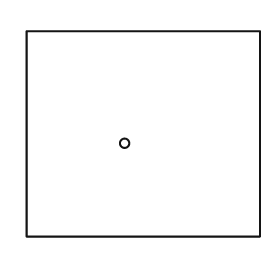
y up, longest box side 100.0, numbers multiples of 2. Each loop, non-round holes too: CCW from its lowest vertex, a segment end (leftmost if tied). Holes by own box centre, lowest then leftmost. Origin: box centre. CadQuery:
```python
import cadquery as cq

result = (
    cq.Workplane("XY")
    .moveTo(-50.0, -44.0)
    .lineTo(50.0, -44.0)
    .lineTo(50.0, 44.0)
    .lineTo(-50.0, 44.0)
    .close()
    .moveTo(-8.0, -4.0)
    .circle(2.0)
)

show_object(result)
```